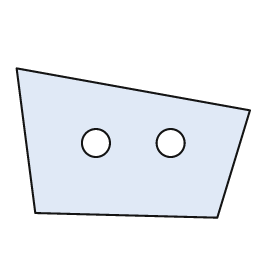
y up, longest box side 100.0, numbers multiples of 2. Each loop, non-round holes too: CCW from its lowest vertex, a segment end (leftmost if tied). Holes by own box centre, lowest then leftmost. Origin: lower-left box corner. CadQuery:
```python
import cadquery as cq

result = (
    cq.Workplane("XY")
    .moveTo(86.0, 0.0)
    .lineTo(100.0, 46.0)
    .lineTo(0.0, 64.0)
    .lineTo(8.0, 2.0)
    .close()
    .moveTo(34.0, 32.0)
    .circle(6.0)
    .moveTo(66.0, 32.0)
    .circle(6.0)
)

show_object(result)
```